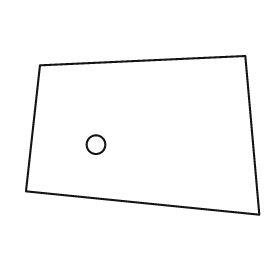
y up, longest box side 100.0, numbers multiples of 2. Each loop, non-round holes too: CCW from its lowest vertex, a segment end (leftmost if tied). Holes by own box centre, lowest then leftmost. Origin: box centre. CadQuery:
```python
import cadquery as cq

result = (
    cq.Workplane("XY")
    .moveTo(50.0, -34.0)
    .lineTo(44.0, 34.0)
    .lineTo(-44.0, 30.0)
    .lineTo(-50.0, -24.0)
    .close()
    .moveTo(-20.0, -4.0)
    .circle(4.0)
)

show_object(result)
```